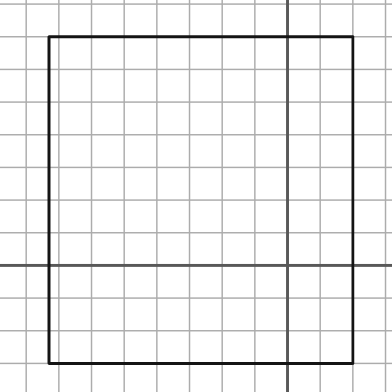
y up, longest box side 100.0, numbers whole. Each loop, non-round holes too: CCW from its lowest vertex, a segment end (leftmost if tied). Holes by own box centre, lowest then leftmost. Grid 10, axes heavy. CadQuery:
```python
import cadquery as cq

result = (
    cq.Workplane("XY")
    .moveTo(-73.0, -30.0)
    .lineTo(20.0, -30.0)
    .lineTo(20.0, 70.0)
    .lineTo(-73.0, 70.0)
    .close()
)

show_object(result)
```